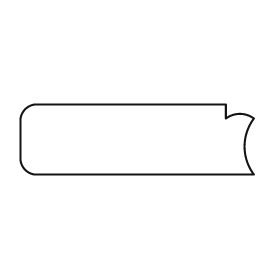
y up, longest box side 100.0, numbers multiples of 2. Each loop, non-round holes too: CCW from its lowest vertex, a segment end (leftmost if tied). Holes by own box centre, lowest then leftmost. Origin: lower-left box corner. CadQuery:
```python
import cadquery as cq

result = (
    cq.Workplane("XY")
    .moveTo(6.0, 0.0)
    .lineTo(100.0, 0.0)
    .threePointArc((96.0, 12.0), (100.0, 24.0))
    .threePointArc((94.0, 26.0), (88.0, 24.0))
    .lineTo(88.0, 30.0)
    .lineTo(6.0, 30.0)
    .threePointArc((2.0, 28.0), (0.0, 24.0))
    .lineTo(0.0, 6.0)
    .threePointArc((2.0, 2.0), (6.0, 0.0))
    .close()
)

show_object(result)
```